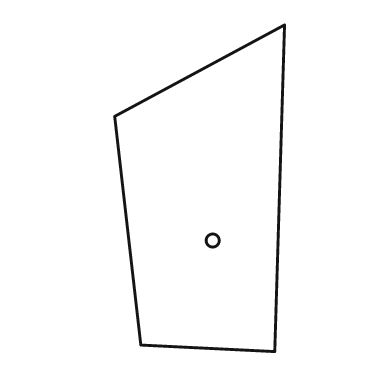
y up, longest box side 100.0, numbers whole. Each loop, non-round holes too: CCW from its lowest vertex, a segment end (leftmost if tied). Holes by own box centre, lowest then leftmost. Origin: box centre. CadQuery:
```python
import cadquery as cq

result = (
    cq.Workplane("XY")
    .moveTo(23.0, -50.0)
    .lineTo(26.0, 50.0)
    .lineTo(-26.0, 22.0)
    .lineTo(-18.0, -48.0)
    .close()
    .moveTo(4.0, -16.0)
    .circle(2.0)
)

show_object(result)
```